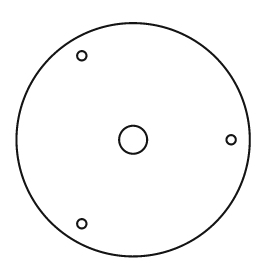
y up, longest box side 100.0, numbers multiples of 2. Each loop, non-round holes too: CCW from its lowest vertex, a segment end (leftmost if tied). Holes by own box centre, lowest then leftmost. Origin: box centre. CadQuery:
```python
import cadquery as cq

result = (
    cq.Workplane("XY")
    .moveTo(0.0, 0.0)
    .circle(50.0)
    .moveTo(-22.0, -36.0)
    .circle(2.0)
    .moveTo(0.0, 0.0)
    .circle(6.0)
    .moveTo(42.0, 0.0)
    .circle(2.0)
    .moveTo(-22.0, 36.0)
    .circle(2.0)
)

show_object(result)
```